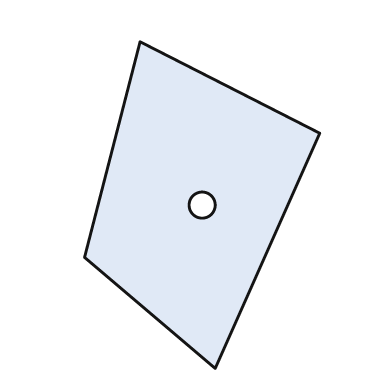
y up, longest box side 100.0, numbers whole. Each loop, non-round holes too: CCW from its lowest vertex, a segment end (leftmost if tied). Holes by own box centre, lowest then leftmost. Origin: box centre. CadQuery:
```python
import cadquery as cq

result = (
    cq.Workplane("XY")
    .moveTo(4.0, -50.0)
    .lineTo(36.0, 22.0)
    .lineTo(-19.0, 50.0)
    .lineTo(-36.0, -16.0)
    .close()
    .moveTo(0.0, 0.0)
    .circle(4.0)
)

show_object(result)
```